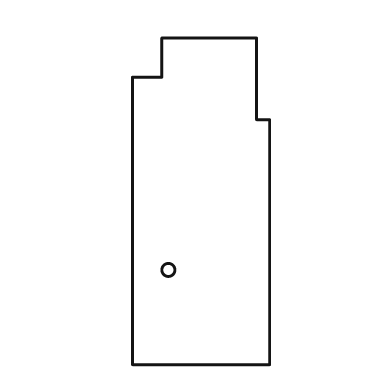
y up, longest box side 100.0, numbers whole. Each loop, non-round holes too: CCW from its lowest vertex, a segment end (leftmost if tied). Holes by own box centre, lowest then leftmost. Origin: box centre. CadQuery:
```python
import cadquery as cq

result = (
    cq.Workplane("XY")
    .moveTo(-21.0, -50.0)
    .lineTo(21.0, -50.0)
    .lineTo(21.0, 25.0)
    .lineTo(17.0, 25.0)
    .lineTo(17.0, 50.0)
    .lineTo(-12.0, 50.0)
    .lineTo(-12.0, 38.0)
    .lineTo(-21.0, 38.0)
    .close()
    .moveTo(-10.0, -21.0)
    .circle(2.0)
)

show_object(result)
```